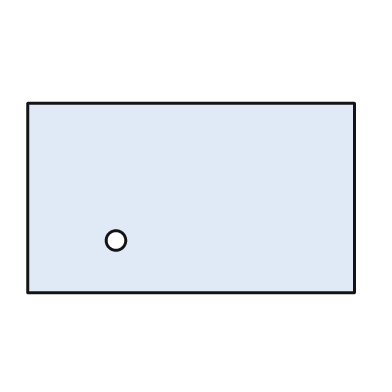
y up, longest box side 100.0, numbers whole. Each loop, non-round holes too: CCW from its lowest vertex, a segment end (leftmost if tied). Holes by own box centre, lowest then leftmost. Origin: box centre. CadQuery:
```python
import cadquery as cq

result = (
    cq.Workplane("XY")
    .moveTo(-50.0, -29.0)
    .lineTo(50.0, -29.0)
    .lineTo(50.0, 29.0)
    .lineTo(-50.0, 29.0)
    .close()
    .moveTo(-23.0, -13.0)
    .circle(3.0)
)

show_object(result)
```